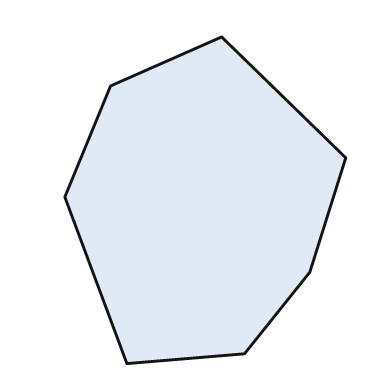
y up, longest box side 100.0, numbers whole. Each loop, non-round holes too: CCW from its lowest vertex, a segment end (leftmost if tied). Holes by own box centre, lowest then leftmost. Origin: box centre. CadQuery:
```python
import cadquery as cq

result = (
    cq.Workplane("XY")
    .moveTo(-24.0, -50.0)
    .lineTo(12.0, -47.0)
    .lineTo(32.0, -22.0)
    .lineTo(43.0, 13.0)
    .lineTo(5.0, 50.0)
    .lineTo(-29.0, 35.0)
    .lineTo(-43.0, 1.0)
    .close()
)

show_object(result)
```